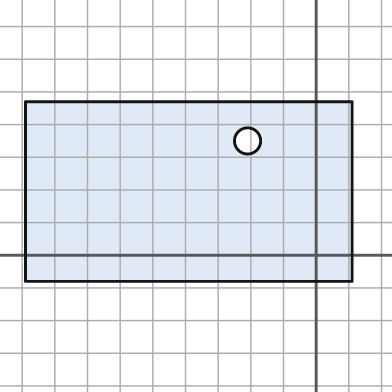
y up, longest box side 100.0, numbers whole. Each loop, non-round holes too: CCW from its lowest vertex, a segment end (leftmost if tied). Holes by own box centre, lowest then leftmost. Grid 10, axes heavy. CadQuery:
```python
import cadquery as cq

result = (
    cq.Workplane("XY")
    .moveTo(-89.0, -8.0)
    .lineTo(11.0, -8.0)
    .lineTo(11.0, 47.0)
    .lineTo(-89.0, 47.0)
    .close()
    .moveTo(-21.0, 35.0)
    .circle(4.0)
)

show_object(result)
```